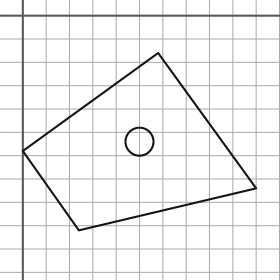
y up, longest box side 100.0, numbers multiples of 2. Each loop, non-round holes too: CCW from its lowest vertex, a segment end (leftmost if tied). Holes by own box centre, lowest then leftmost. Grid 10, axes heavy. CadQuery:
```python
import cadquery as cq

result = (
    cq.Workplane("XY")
    .moveTo(24.0, -92.0)
    .lineTo(100.0, -74.0)
    .lineTo(58.0, -16.0)
    .lineTo(0.0, -58.0)
    .close()
    .moveTo(50.0, -54.0)
    .circle(6.0)
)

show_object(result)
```